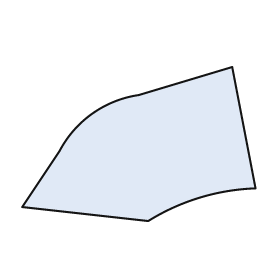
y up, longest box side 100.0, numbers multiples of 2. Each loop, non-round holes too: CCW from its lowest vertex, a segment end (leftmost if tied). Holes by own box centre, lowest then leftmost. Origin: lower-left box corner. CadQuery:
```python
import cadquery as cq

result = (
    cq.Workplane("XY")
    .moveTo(54.0, 0.0)
    .threePointArc((76.0, 10.0), (100.0, 14.0))
    .lineTo(90.0, 66.0)
    .lineTo(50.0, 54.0)
    .threePointArc((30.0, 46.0), (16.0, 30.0))
    .lineTo(0.0, 6.0)
    .close()
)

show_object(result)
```